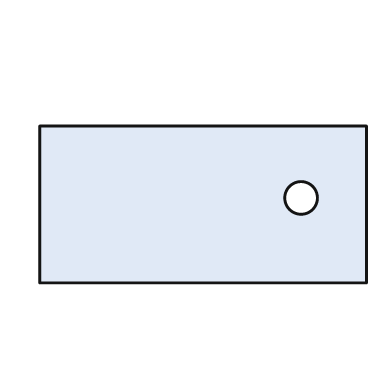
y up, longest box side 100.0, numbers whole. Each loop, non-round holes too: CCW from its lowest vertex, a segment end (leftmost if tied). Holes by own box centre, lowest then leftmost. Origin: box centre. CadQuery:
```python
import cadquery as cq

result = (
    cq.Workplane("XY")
    .moveTo(-50.0, -24.0)
    .lineTo(50.0, -24.0)
    .lineTo(50.0, 24.0)
    .lineTo(-50.0, 24.0)
    .close()
    .moveTo(30.0, 2.0)
    .circle(5.0)
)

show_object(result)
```